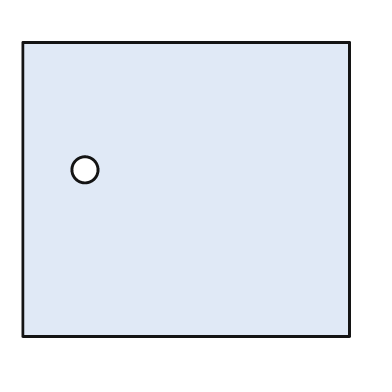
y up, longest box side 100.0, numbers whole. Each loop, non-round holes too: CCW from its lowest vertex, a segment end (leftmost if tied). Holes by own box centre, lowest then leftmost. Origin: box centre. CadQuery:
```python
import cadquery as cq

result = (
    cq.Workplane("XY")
    .moveTo(-50.0, -45.0)
    .lineTo(50.0, -45.0)
    .lineTo(50.0, 45.0)
    .lineTo(-50.0, 45.0)
    .close()
    .moveTo(-31.0, 6.0)
    .circle(4.0)
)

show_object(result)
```